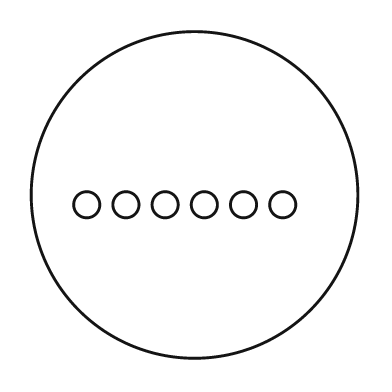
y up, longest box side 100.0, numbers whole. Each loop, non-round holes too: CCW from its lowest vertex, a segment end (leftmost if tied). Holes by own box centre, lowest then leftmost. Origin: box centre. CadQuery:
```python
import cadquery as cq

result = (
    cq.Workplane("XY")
    .moveTo(0.0, 0.0)
    .circle(50.0)
    .moveTo(-33.0, -3.0)
    .circle(4.0)
    .moveTo(-21.0, -3.0)
    .circle(4.0)
    .moveTo(-9.0, -3.0)
    .circle(4.0)
    .moveTo(3.0, -3.0)
    .circle(4.0)
    .moveTo(15.0, -3.0)
    .circle(4.0)
    .moveTo(27.0, -3.0)
    .circle(4.0)
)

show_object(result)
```